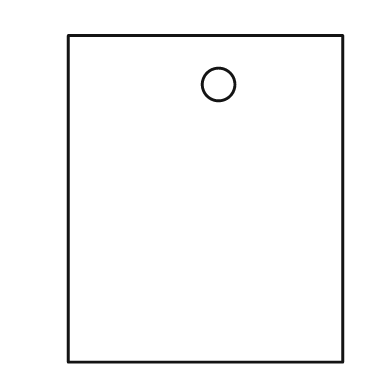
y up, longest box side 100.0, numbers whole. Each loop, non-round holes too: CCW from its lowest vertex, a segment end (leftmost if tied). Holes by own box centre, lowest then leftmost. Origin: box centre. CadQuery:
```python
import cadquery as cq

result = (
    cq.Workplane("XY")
    .moveTo(-42.0, -50.0)
    .lineTo(42.0, -50.0)
    .lineTo(42.0, 50.0)
    .lineTo(-42.0, 50.0)
    .close()
    .moveTo(4.0, 35.0)
    .circle(5.0)
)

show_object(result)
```